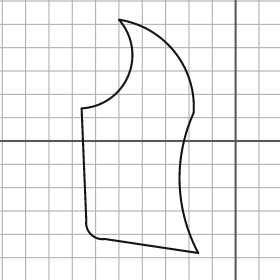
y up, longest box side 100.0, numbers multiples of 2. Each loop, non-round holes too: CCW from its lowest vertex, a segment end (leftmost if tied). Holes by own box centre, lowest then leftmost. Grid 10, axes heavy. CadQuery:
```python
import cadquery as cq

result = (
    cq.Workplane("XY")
    .moveTo(-16.0, -48.0)
    .threePointArc((-24.0, -18.0), (-18.0, 12.0))
    .threePointArc((-26.0, 38.0), (-50.0, 52.0))
    .threePointArc((-46.0, 28.0), (-66.0, 14.0))
    .lineTo(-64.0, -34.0)
    .threePointArc((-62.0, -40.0), (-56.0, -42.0))
    .close()
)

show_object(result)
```